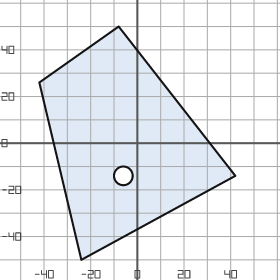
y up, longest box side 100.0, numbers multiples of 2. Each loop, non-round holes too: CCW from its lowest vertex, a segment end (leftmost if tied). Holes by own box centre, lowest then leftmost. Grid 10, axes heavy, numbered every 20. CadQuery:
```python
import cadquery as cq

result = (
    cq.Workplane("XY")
    .moveTo(-24.0, -50.0)
    .lineTo(42.0, -14.0)
    .lineTo(-8.0, 50.0)
    .lineTo(-42.0, 26.0)
    .close()
    .moveTo(-6.0, -14.0)
    .circle(4.0)
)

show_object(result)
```